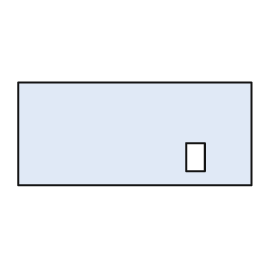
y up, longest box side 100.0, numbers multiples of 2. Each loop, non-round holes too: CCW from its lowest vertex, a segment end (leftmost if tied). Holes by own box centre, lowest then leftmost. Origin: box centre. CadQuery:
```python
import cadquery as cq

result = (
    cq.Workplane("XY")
    .moveTo(-50.0, -22.0)
    .lineTo(50.0, -22.0)
    .lineTo(50.0, 22.0)
    .lineTo(-50.0, 22.0)
    .close()
    .moveTo(22.0, -16.0)
    .lineTo(30.0, -16.0)
    .lineTo(30.0, -4.0)
    .lineTo(22.0, -4.0)
    .close()
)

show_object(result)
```